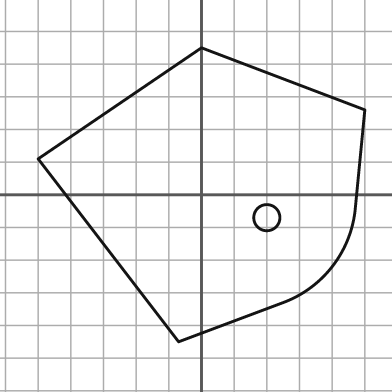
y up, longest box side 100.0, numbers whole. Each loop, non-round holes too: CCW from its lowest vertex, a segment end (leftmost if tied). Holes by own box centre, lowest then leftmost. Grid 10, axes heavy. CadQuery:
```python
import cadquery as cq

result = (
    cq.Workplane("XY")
    .moveTo(-7.0, -45.0)
    .lineTo(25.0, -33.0)
    .threePointArc((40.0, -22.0), (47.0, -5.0))
    .lineTo(50.0, 26.0)
    .lineTo(0.0, 45.0)
    .lineTo(-50.0, 11.0)
    .close()
    .moveTo(20.0, -7.0)
    .circle(4.0)
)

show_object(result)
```